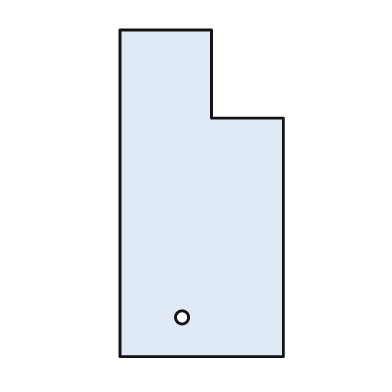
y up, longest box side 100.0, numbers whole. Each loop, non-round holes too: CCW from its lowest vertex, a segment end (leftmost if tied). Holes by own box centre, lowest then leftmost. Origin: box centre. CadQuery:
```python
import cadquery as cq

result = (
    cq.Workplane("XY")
    .moveTo(-25.0, -50.0)
    .lineTo(25.0, -50.0)
    .lineTo(25.0, 23.0)
    .lineTo(3.0, 23.0)
    .lineTo(3.0, 50.0)
    .lineTo(-25.0, 50.0)
    .close()
    .moveTo(-6.0, -38.0)
    .circle(2.0)
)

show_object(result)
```